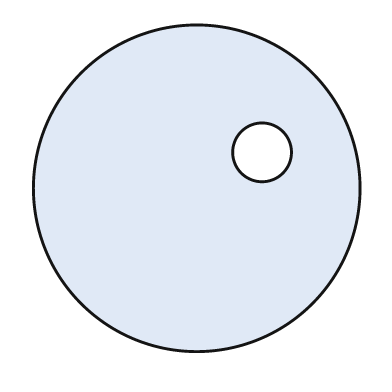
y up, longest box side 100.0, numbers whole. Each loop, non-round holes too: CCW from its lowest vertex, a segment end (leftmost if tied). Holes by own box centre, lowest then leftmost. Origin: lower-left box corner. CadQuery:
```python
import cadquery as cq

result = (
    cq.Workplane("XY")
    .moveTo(50.0, 50.0)
    .circle(50.0)
    .moveTo(70.0, 61.0)
    .circle(9.0)
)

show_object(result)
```